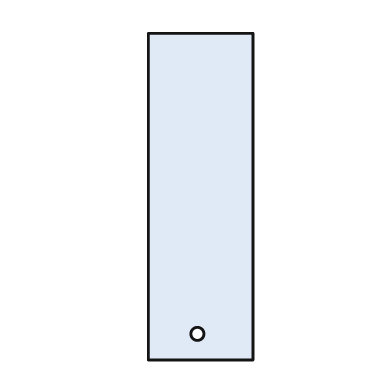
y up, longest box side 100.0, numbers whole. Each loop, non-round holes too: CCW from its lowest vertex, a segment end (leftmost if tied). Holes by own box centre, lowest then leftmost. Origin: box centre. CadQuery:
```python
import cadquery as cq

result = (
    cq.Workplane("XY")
    .moveTo(-16.0, -50.0)
    .lineTo(16.0, -50.0)
    .lineTo(16.0, 50.0)
    .lineTo(-16.0, 50.0)
    .close()
    .moveTo(-1.0, -42.0)
    .circle(2.0)
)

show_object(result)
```